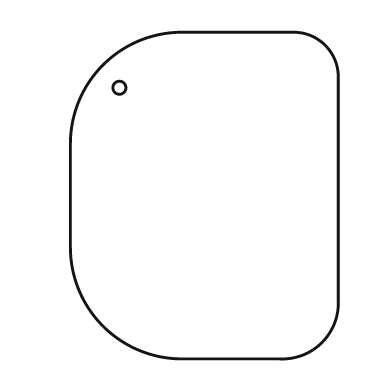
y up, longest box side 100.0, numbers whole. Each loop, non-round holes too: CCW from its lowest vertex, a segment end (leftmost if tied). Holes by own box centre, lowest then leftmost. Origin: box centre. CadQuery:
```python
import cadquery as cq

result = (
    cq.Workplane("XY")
    .moveTo(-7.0, -50.0)
    .lineTo(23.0, -50.0)
    .threePointArc((36.0, -45.0), (41.0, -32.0))
    .lineTo(41.0, 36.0)
    .threePointArc((37.0, 46.0), (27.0, 50.0))
    .lineTo(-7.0, 50.0)
    .threePointArc((-31.0, 40.0), (-41.0, 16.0))
    .lineTo(-41.0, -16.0)
    .threePointArc((-31.0, -40.0), (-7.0, -50.0))
    .close()
    .moveTo(-26.0, 33.0)
    .circle(2.0)
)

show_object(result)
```